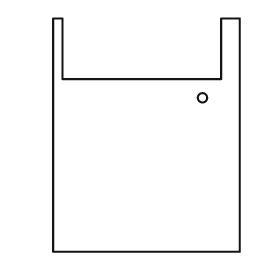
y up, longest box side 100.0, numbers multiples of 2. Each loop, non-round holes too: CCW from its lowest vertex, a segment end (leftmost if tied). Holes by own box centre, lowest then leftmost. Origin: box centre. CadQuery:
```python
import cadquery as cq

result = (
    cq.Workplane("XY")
    .moveTo(-40.0, -50.0)
    .lineTo(40.0, -50.0)
    .lineTo(40.0, 50.0)
    .lineTo(32.0, 50.0)
    .lineTo(32.0, 24.0)
    .lineTo(-36.0, 24.0)
    .lineTo(-36.0, 50.0)
    .lineTo(-40.0, 50.0)
    .close()
    .moveTo(24.0, 16.0)
    .circle(2.0)
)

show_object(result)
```